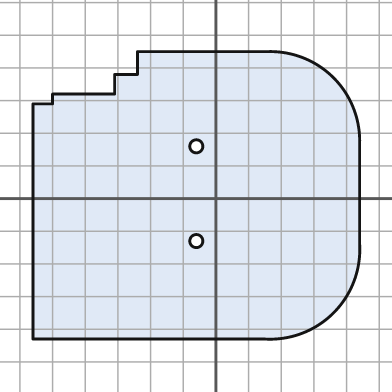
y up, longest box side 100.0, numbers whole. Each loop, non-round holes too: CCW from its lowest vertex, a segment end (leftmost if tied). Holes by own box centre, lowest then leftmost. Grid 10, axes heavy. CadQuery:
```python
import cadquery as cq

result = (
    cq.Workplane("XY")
    .moveTo(-56.0, -43.0)
    .lineTo(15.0, -43.0)
    .threePointArc((36.0, -35.0), (44.0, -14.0))
    .lineTo(44.0, 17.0)
    .threePointArc((36.0, 37.0), (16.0, 45.0))
    .lineTo(-24.0, 45.0)
    .lineTo(-24.0, 38.0)
    .lineTo(-31.0, 38.0)
    .lineTo(-31.0, 32.0)
    .lineTo(-50.0, 32.0)
    .lineTo(-50.0, 29.0)
    .lineTo(-56.0, 29.0)
    .close()
    .moveTo(-6.0, -13.0)
    .circle(2.0)
    .moveTo(-6.0, 16.0)
    .circle(2.0)
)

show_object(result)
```